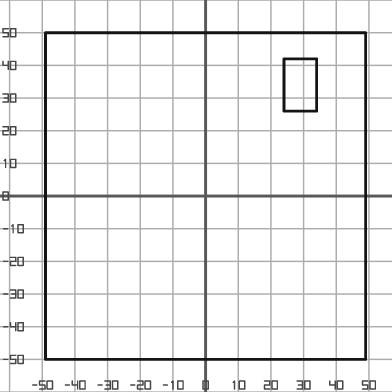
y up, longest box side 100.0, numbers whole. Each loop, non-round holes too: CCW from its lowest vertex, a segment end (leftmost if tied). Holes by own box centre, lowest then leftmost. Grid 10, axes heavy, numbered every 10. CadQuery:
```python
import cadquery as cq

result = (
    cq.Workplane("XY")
    .moveTo(-49.0, -50.0)
    .lineTo(49.0, -50.0)
    .lineTo(49.0, 50.0)
    .lineTo(-49.0, 50.0)
    .close()
    .moveTo(24.0, 26.0)
    .lineTo(34.0, 26.0)
    .lineTo(34.0, 42.0)
    .lineTo(24.0, 42.0)
    .close()
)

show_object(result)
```